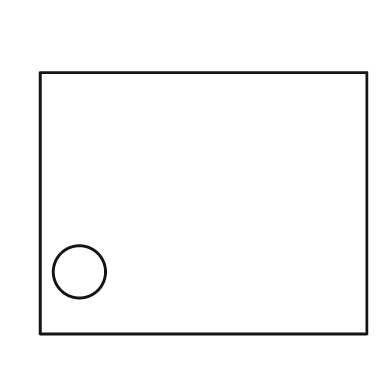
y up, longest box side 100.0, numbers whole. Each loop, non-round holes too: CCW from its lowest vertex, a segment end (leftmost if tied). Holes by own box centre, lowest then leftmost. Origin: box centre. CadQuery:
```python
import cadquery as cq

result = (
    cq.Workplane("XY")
    .moveTo(-50.0, -40.0)
    .lineTo(50.0, -40.0)
    .lineTo(50.0, 40.0)
    .lineTo(-50.0, 40.0)
    .close()
    .moveTo(-38.0, -21.0)
    .circle(8.0)
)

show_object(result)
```